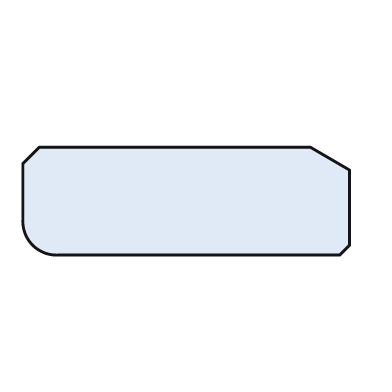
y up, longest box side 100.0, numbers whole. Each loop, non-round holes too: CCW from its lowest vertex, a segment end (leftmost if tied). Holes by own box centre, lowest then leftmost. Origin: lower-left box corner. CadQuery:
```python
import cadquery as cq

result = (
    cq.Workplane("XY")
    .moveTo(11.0, 0.0)
    .lineTo(97.0, 0.0)
    .lineTo(100.0, 3.0)
    .lineTo(100.0, 26.0)
    .lineTo(88.0, 33.0)
    .lineTo(5.0, 33.0)
    .lineTo(0.0, 28.0)
    .lineTo(0.0, 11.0)
    .threePointArc((3.0, 3.0), (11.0, 0.0))
    .close()
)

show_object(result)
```